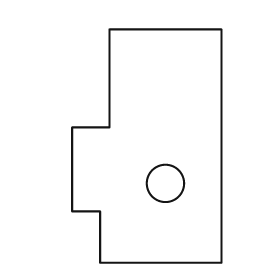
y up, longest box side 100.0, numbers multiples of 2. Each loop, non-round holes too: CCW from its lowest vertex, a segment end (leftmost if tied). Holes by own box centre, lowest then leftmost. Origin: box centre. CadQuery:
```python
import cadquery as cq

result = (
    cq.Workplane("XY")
    .moveTo(-20.0, -50.0)
    .lineTo(32.0, -50.0)
    .lineTo(32.0, 50.0)
    .lineTo(-16.0, 50.0)
    .lineTo(-16.0, 8.0)
    .lineTo(-32.0, 8.0)
    .lineTo(-32.0, -28.0)
    .lineTo(-20.0, -28.0)
    .close()
    .moveTo(8.0, -16.0)
    .circle(8.0)
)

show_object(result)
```